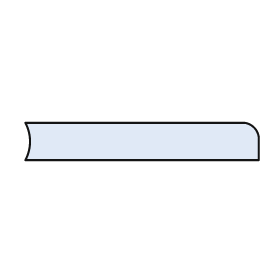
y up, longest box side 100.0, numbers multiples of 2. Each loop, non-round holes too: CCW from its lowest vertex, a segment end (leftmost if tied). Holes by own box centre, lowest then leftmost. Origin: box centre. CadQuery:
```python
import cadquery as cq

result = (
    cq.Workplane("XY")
    .moveTo(-50.0, -8.0)
    .lineTo(50.0, -8.0)
    .lineTo(50.0, 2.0)
    .threePointArc((48.0, 6.0), (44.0, 8.0))
    .lineTo(-50.0, 8.0)
    .threePointArc((-48.0, 0.0), (-50.0, -8.0))
    .close()
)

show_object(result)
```